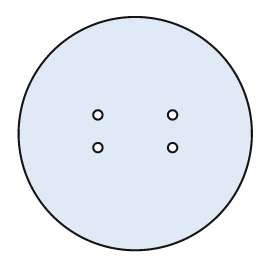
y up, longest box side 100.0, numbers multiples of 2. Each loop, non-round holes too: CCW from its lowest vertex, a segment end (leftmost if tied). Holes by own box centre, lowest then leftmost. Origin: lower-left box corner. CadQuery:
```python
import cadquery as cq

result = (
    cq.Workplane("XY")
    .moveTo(50.0, 50.0)
    .circle(50.0)
    .moveTo(34.0, 44.0)
    .circle(2.0)
    .moveTo(66.0, 44.0)
    .circle(2.0)
    .moveTo(34.0, 58.0)
    .circle(2.0)
    .moveTo(66.0, 58.0)
    .circle(2.0)
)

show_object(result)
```